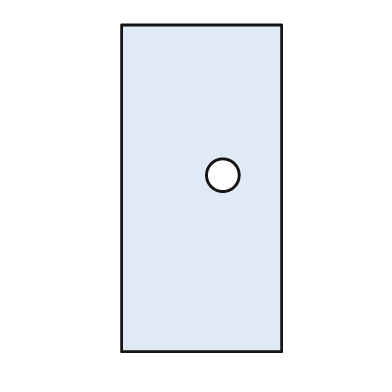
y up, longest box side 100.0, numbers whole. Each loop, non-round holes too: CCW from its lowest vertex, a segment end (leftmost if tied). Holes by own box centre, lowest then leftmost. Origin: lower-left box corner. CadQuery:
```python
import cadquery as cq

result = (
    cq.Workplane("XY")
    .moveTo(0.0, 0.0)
    .lineTo(49.0, 0.0)
    .lineTo(49.0, 100.0)
    .lineTo(0.0, 100.0)
    .close()
    .moveTo(31.0, 54.0)
    .circle(5.0)
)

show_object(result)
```